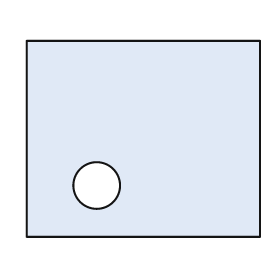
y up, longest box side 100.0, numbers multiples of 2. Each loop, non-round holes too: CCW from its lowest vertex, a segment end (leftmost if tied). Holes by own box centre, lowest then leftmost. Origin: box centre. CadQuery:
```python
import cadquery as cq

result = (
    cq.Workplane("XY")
    .moveTo(-50.0, -42.0)
    .lineTo(50.0, -42.0)
    .lineTo(50.0, 42.0)
    .lineTo(-50.0, 42.0)
    .close()
    .moveTo(-20.0, -20.0)
    .circle(10.0)
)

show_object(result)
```